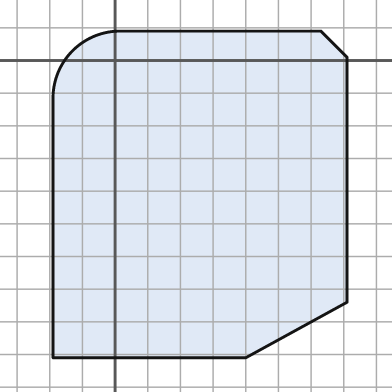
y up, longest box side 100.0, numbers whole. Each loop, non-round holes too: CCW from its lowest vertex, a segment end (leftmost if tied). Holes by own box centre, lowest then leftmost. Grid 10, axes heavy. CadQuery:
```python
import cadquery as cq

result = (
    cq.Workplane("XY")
    .moveTo(-19.0, -91.0)
    .lineTo(40.0, -91.0)
    .lineTo(71.0, -74.0)
    .lineTo(71.0, 1.0)
    .lineTo(63.0, 9.0)
    .lineTo(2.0, 9.0)
    .threePointArc((-13.0, 3.0), (-19.0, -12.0))
    .close()
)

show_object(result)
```